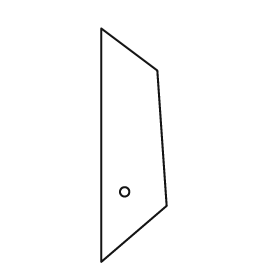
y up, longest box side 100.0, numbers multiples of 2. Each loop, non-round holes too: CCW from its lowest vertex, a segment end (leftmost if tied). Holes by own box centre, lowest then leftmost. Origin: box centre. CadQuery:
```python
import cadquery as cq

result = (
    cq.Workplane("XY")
    .moveTo(-14.0, -50.0)
    .lineTo(14.0, -26.0)
    .lineTo(10.0, 32.0)
    .lineTo(-14.0, 50.0)
    .close()
    .moveTo(-4.0, -20.0)
    .circle(2.0)
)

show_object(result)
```